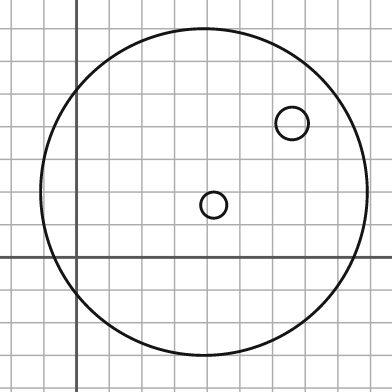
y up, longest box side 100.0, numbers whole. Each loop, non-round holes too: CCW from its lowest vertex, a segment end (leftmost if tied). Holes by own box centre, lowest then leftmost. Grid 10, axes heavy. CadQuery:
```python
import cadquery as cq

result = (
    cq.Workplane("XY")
    .moveTo(39.0, 20.0)
    .circle(50.0)
    .moveTo(42.0, 16.0)
    .circle(4.0)
    .moveTo(66.0, 41.0)
    .circle(5.0)
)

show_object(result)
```